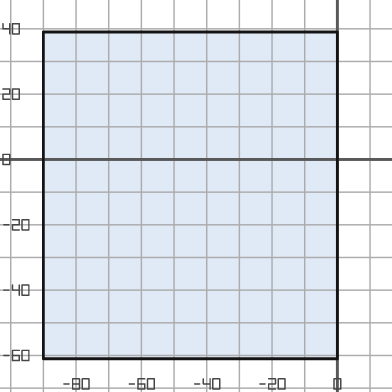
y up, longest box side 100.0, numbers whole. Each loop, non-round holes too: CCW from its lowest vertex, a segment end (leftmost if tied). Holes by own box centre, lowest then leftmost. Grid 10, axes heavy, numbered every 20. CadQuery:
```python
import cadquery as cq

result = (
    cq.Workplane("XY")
    .moveTo(-90.0, -61.0)
    .lineTo(0.0, -61.0)
    .lineTo(0.0, 39.0)
    .lineTo(-90.0, 39.0)
    .close()
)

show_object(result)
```